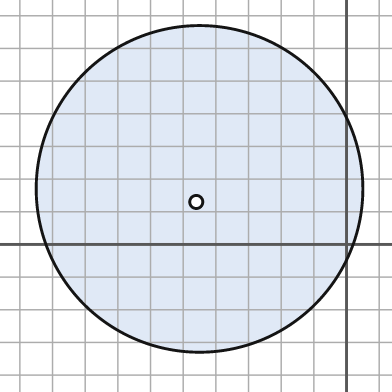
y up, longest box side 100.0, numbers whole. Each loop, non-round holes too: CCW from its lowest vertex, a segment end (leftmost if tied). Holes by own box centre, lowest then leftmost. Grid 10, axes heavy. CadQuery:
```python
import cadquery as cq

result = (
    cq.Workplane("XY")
    .moveTo(-45.0, 17.0)
    .circle(50.0)
    .moveTo(-46.0, 13.0)
    .circle(2.0)
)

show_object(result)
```